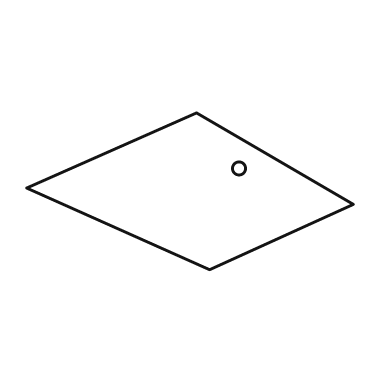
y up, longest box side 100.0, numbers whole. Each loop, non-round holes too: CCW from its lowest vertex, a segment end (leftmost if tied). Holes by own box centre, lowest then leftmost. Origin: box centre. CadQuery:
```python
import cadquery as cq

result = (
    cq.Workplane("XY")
    .moveTo(6.0, -24.0)
    .lineTo(50.0, -4.0)
    .lineTo(2.0, 24.0)
    .lineTo(-50.0, 1.0)
    .close()
    .moveTo(15.0, 7.0)
    .circle(2.0)
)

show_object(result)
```